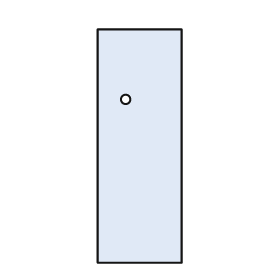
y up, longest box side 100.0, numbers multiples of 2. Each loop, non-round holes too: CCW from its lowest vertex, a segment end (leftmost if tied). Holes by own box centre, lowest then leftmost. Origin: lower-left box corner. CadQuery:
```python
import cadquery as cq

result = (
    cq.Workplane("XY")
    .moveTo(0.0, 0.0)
    .lineTo(36.0, 0.0)
    .lineTo(36.0, 100.0)
    .lineTo(0.0, 100.0)
    .close()
    .moveTo(12.0, 70.0)
    .circle(2.0)
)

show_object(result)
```